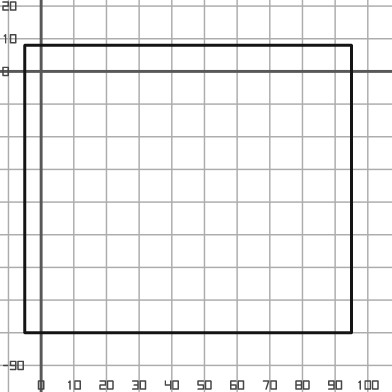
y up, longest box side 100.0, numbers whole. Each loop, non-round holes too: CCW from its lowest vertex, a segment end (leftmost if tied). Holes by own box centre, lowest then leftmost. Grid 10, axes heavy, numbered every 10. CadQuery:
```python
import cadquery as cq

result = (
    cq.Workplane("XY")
    .moveTo(-5.0, -80.0)
    .lineTo(95.0, -80.0)
    .lineTo(95.0, 8.0)
    .lineTo(-5.0, 8.0)
    .close()
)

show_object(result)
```